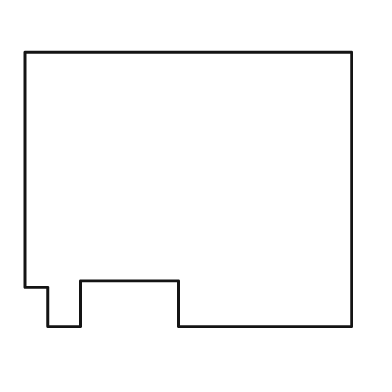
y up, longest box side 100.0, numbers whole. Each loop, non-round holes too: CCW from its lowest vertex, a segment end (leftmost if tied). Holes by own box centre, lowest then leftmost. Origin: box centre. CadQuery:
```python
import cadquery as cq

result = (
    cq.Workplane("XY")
    .moveTo(-43.0, -42.0)
    .lineTo(-33.0, -42.0)
    .lineTo(-33.0, -28.0)
    .lineTo(-3.0, -28.0)
    .lineTo(-3.0, -42.0)
    .lineTo(50.0, -42.0)
    .lineTo(50.0, 42.0)
    .lineTo(-50.0, 42.0)
    .lineTo(-50.0, -30.0)
    .lineTo(-43.0, -30.0)
    .close()
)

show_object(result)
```